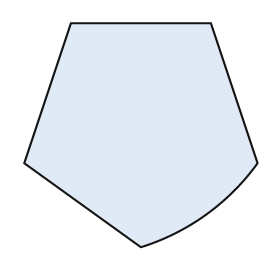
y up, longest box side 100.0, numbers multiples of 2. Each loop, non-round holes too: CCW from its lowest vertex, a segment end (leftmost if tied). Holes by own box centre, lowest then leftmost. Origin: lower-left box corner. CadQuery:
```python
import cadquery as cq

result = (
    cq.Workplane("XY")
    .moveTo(50.0, 0.0)
    .threePointArc((78.0, 14.0), (100.0, 36.0))
    .lineTo(80.0, 96.0)
    .lineTo(20.0, 96.0)
    .lineTo(0.0, 36.0)
    .close()
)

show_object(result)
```